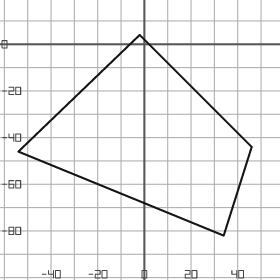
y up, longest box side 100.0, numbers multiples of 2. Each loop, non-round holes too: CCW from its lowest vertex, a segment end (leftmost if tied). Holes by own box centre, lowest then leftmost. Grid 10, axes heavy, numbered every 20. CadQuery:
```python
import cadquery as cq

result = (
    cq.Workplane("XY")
    .moveTo(34.0, -82.0)
    .lineTo(46.0, -44.0)
    .lineTo(-2.0, 4.0)
    .lineTo(-54.0, -46.0)
    .close()
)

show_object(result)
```